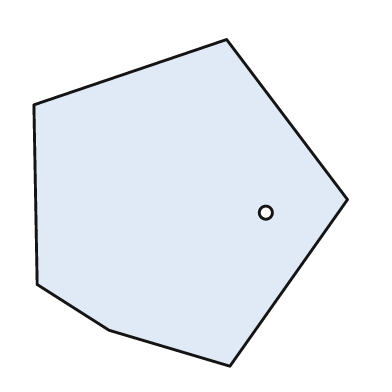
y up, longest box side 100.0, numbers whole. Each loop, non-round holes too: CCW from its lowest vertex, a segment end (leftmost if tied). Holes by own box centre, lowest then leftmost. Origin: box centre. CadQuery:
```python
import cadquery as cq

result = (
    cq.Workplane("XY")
    .moveTo(12.0, -50.0)
    .lineTo(48.0, 1.0)
    .lineTo(11.0, 50.0)
    .lineTo(-48.0, 30.0)
    .lineTo(-47.0, -25.0)
    .lineTo(-25.0, -39.0)
    .close()
    .moveTo(23.0, -3.0)
    .circle(2.0)
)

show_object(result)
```